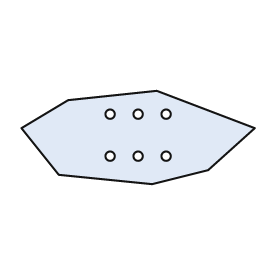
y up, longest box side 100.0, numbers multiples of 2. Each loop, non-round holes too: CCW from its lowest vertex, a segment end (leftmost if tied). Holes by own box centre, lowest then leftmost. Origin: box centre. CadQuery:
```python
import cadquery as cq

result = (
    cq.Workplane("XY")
    .moveTo(6.0, -20.0)
    .lineTo(30.0, -14.0)
    .lineTo(50.0, 4.0)
    .lineTo(8.0, 20.0)
    .lineTo(-30.0, 16.0)
    .lineTo(-50.0, 4.0)
    .lineTo(-34.0, -16.0)
    .close()
    .moveTo(-12.0, -8.0)
    .circle(2.0)
    .moveTo(0.0, -8.0)
    .circle(2.0)
    .moveTo(12.0, -8.0)
    .circle(2.0)
    .moveTo(-12.0, 10.0)
    .circle(2.0)
    .moveTo(0.0, 10.0)
    .circle(2.0)
    .moveTo(12.0, 10.0)
    .circle(2.0)
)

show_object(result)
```